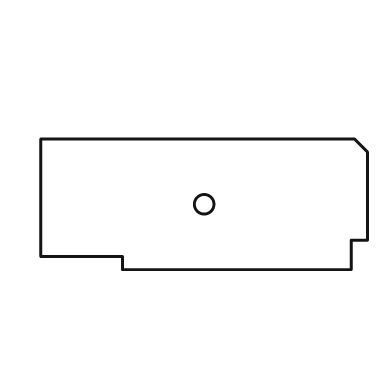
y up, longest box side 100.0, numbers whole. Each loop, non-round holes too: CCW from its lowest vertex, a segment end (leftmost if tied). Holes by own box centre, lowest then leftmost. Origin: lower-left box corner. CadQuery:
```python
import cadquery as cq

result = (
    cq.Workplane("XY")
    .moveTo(25.0, 0.0)
    .lineTo(95.0, 0.0)
    .lineTo(95.0, 9.0)
    .lineTo(100.0, 9.0)
    .lineTo(100.0, 36.0)
    .lineTo(96.0, 40.0)
    .lineTo(0.0, 40.0)
    .lineTo(0.0, 4.0)
    .lineTo(25.0, 4.0)
    .close()
    .moveTo(50.0, 20.0)
    .circle(3.0)
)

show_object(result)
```